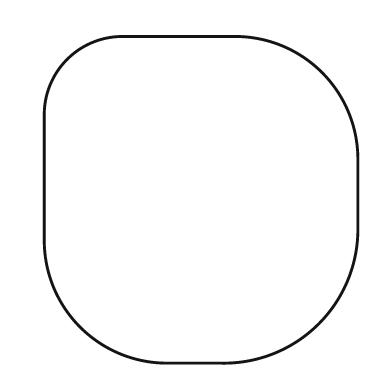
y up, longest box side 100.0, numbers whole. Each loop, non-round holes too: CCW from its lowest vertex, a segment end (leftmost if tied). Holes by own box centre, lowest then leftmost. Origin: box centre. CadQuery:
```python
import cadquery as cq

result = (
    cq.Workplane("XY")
    .moveTo(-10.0, -50.0)
    .lineTo(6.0, -50.0)
    .threePointArc((36.0, -38.0), (48.0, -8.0))
    .lineTo(48.0, 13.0)
    .threePointArc((37.0, 39.0), (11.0, 50.0))
    .lineTo(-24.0, 50.0)
    .threePointArc((-41.0, 43.0), (-48.0, 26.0))
    .lineTo(-48.0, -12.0)
    .threePointArc((-37.0, -39.0), (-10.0, -50.0))
    .close()
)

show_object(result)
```